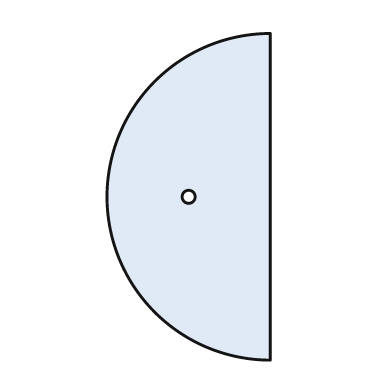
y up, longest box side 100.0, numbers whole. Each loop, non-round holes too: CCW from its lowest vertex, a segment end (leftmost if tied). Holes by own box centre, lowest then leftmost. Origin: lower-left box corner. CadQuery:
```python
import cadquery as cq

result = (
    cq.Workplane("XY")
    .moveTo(50.0, 0.0)
    .lineTo(50.0, 100.0)
    .threePointArc((0.0, 50.0), (50.0, 0.0))
    .close()
    .moveTo(25.0, 50.0)
    .circle(2.0)
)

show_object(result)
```